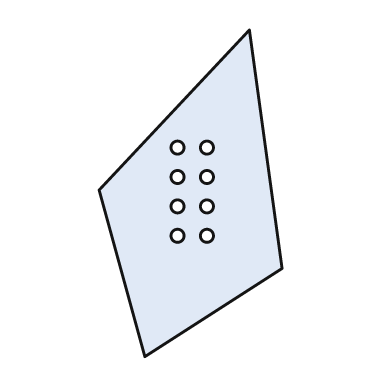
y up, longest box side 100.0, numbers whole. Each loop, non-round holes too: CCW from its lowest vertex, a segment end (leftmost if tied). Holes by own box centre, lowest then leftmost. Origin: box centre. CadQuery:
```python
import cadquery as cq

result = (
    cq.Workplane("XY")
    .moveTo(-14.0, -50.0)
    .lineTo(28.0, -23.0)
    .lineTo(18.0, 50.0)
    .lineTo(-28.0, 1.0)
    .close()
    .moveTo(-4.0, -13.0)
    .circle(2.0)
    .moveTo(5.0, -13.0)
    .circle(2.0)
    .moveTo(-4.0, -4.0)
    .circle(2.0)
    .moveTo(5.0, -4.0)
    .circle(2.0)
    .moveTo(-4.0, 5.0)
    .circle(2.0)
    .moveTo(5.0, 5.0)
    .circle(2.0)
    .moveTo(-4.0, 14.0)
    .circle(2.0)
    .moveTo(5.0, 14.0)
    .circle(2.0)
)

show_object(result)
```